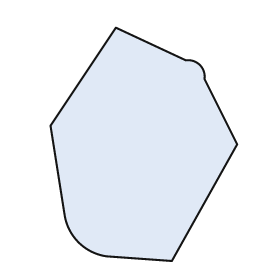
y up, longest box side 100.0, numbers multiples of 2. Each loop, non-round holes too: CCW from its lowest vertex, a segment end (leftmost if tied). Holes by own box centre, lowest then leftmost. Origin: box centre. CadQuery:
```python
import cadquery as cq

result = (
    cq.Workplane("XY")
    .moveTo(12.0, -50.0)
    .lineTo(40.0, 0.0)
    .lineTo(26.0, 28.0)
    .threePointArc((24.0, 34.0), (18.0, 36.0))
    .lineTo(-12.0, 50.0)
    .lineTo(-40.0, 8.0)
    .lineTo(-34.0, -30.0)
    .threePointArc((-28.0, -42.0), (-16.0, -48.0))
    .close()
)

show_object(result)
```